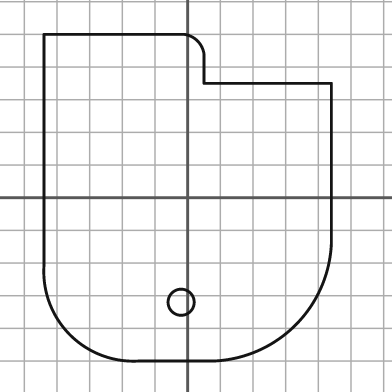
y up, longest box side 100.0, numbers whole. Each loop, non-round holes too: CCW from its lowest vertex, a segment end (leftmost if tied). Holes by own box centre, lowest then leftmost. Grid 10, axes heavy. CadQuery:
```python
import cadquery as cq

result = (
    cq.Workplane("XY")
    .moveTo(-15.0, -50.0)
    .lineTo(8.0, -50.0)
    .threePointArc((33.0, -39.0), (44.0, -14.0))
    .lineTo(44.0, 35.0)
    .lineTo(5.0, 35.0)
    .lineTo(5.0, 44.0)
    .threePointArc((3.0, 48.0), (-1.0, 50.0))
    .lineTo(-44.0, 50.0)
    .lineTo(-44.0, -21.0)
    .threePointArc((-36.0, -42.0), (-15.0, -50.0))
    .close()
    .moveTo(-2.0, -32.0)
    .circle(4.0)
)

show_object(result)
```